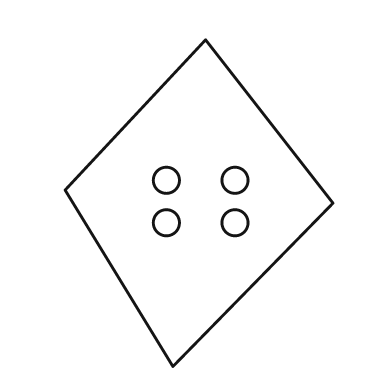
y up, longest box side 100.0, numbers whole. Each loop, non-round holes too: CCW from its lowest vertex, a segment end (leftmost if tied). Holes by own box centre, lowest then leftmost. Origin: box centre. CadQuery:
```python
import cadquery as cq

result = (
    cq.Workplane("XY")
    .moveTo(-8.0, -50.0)
    .lineTo(41.0, 0.0)
    .lineTo(2.0, 50.0)
    .lineTo(-41.0, 4.0)
    .close()
    .moveTo(-10.0, -6.0)
    .circle(4.0)
    .moveTo(11.0, -6.0)
    .circle(4.0)
    .moveTo(-10.0, 7.0)
    .circle(4.0)
    .moveTo(11.0, 7.0)
    .circle(4.0)
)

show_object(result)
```